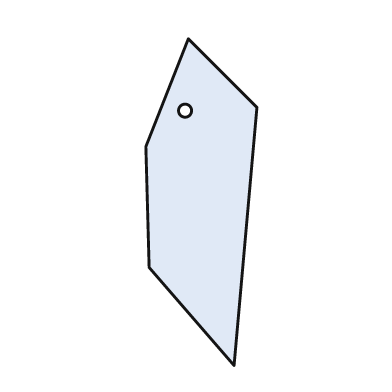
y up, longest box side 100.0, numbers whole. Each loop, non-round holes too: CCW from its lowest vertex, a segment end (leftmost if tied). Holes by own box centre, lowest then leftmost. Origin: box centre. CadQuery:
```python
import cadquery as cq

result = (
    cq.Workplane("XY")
    .moveTo(10.0, -50.0)
    .lineTo(17.0, 29.0)
    .lineTo(-4.0, 50.0)
    .lineTo(-17.0, 17.0)
    .lineTo(-16.0, -20.0)
    .close()
    .moveTo(-5.0, 28.0)
    .circle(2.0)
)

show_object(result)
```